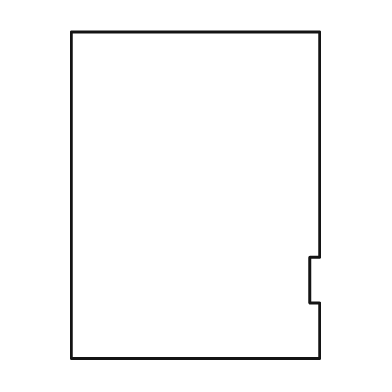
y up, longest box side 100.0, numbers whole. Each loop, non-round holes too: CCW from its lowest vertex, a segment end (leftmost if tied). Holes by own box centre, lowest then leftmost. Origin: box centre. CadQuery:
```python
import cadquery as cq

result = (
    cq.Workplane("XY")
    .moveTo(-38.0, -50.0)
    .lineTo(38.0, -50.0)
    .lineTo(38.0, -33.0)
    .lineTo(35.0, -33.0)
    .lineTo(35.0, -19.0)
    .lineTo(38.0, -19.0)
    .lineTo(38.0, 50.0)
    .lineTo(-38.0, 50.0)
    .close()
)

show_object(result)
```